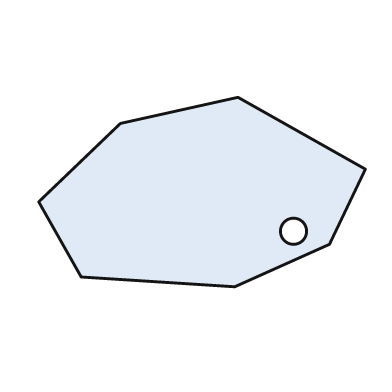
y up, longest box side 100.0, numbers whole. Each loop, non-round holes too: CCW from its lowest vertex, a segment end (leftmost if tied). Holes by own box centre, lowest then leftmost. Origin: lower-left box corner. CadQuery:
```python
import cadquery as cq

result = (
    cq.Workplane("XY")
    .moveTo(60.0, 0.0)
    .lineTo(89.0, 13.0)
    .lineTo(100.0, 36.0)
    .lineTo(61.0, 58.0)
    .lineTo(25.0, 50.0)
    .lineTo(0.0, 26.0)
    .lineTo(13.0, 3.0)
    .close()
    .moveTo(78.0, 17.0)
    .circle(4.0)
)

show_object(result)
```